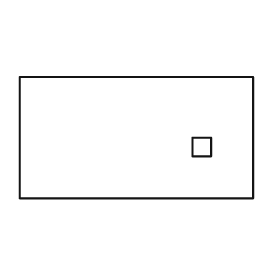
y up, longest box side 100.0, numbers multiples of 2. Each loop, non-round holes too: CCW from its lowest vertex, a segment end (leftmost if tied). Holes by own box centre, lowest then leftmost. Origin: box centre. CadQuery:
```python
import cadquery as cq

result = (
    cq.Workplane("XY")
    .moveTo(-50.0, -26.0)
    .lineTo(50.0, -26.0)
    .lineTo(50.0, 26.0)
    .lineTo(-50.0, 26.0)
    .close()
    .moveTo(24.0, -8.0)
    .lineTo(32.0, -8.0)
    .lineTo(32.0, 0.0)
    .lineTo(24.0, 0.0)
    .close()
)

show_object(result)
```